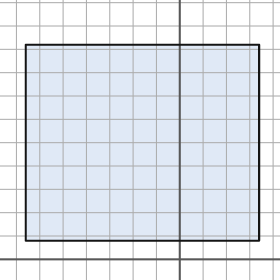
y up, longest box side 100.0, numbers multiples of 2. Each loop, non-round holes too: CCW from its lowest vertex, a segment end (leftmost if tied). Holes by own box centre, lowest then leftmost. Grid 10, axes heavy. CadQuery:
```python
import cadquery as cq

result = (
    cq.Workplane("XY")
    .moveTo(-66.0, 8.0)
    .lineTo(34.0, 8.0)
    .lineTo(34.0, 92.0)
    .lineTo(-66.0, 92.0)
    .close()
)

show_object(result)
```